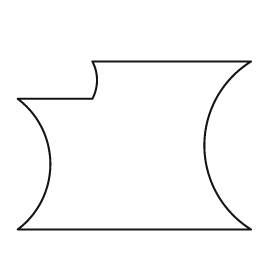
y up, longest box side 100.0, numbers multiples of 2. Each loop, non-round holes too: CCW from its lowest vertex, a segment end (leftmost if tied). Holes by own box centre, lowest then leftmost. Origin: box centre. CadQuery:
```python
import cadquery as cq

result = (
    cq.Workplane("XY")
    .moveTo(-50.0, -36.0)
    .lineTo(50.0, -36.0)
    .threePointArc((30.0, 0.0), (50.0, 36.0))
    .lineTo(-18.0, 36.0)
    .threePointArc((-16.0, 28.0), (-18.0, 20.0))
    .lineTo(-50.0, 20.0)
    .threePointArc((-36.0, -8.0), (-50.0, -36.0))
    .close()
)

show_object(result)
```